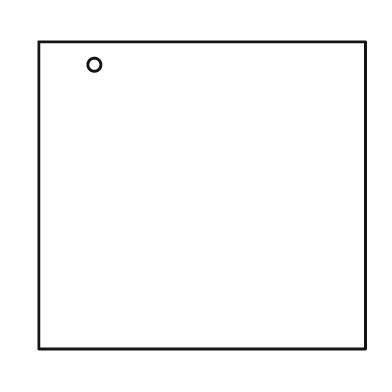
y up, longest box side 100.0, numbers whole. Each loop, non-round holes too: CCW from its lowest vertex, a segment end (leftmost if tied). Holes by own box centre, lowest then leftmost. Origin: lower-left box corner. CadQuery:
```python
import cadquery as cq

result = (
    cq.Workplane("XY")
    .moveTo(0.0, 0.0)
    .lineTo(100.0, 0.0)
    .lineTo(100.0, 94.0)
    .lineTo(0.0, 94.0)
    .close()
    .moveTo(17.0, 87.0)
    .circle(2.0)
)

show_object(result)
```